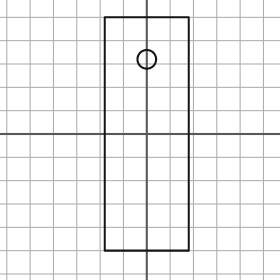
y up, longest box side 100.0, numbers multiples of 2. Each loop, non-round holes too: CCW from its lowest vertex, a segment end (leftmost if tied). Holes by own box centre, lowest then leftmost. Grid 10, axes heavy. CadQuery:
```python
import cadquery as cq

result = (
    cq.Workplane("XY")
    .moveTo(-18.0, -50.0)
    .lineTo(18.0, -50.0)
    .lineTo(18.0, 50.0)
    .lineTo(-18.0, 50.0)
    .close()
    .moveTo(0.0, 32.0)
    .circle(4.0)
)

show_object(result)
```